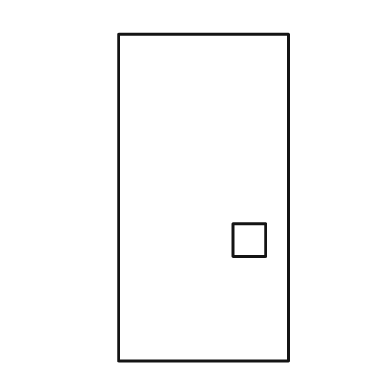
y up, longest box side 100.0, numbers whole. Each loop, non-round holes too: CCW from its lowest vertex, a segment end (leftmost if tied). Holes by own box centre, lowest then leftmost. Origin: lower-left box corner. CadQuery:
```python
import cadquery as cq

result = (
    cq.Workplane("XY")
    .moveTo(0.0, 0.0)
    .lineTo(52.0, 0.0)
    .lineTo(52.0, 100.0)
    .lineTo(0.0, 100.0)
    .close()
    .moveTo(35.0, 32.0)
    .lineTo(45.0, 32.0)
    .lineTo(45.0, 42.0)
    .lineTo(35.0, 42.0)
    .close()
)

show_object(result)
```